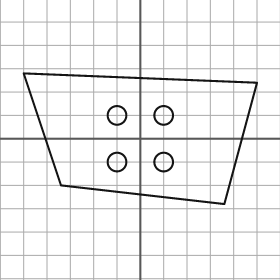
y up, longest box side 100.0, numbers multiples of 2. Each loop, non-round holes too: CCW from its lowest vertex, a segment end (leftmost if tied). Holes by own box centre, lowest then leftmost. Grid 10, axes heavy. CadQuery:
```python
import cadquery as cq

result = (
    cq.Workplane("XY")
    .moveTo(36.0, -28.0)
    .lineTo(50.0, 24.0)
    .lineTo(-50.0, 28.0)
    .lineTo(-34.0, -20.0)
    .close()
    .moveTo(-10.0, -10.0)
    .circle(4.0)
    .moveTo(10.0, -10.0)
    .circle(4.0)
    .moveTo(-10.0, 10.0)
    .circle(4.0)
    .moveTo(10.0, 10.0)
    .circle(4.0)
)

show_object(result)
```